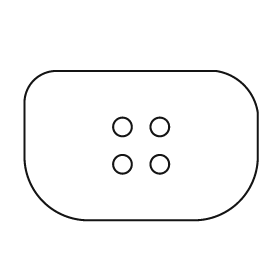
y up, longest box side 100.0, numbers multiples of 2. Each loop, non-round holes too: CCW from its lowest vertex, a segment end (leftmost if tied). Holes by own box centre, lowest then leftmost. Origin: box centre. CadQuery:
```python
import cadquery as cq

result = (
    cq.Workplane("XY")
    .moveTo(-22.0, -32.0)
    .lineTo(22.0, -32.0)
    .threePointArc((42.0, -24.0), (50.0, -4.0))
    .lineTo(50.0, 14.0)
    .threePointArc((44.0, 26.0), (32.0, 32.0))
    .lineTo(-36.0, 32.0)
    .threePointArc((-46.0, 28.0), (-50.0, 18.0))
    .lineTo(-50.0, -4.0)
    .threePointArc((-42.0, -24.0), (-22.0, -32.0))
    .close()
    .moveTo(-8.0, -8.0)
    .circle(4.0)
    .moveTo(8.0, -8.0)
    .circle(4.0)
    .moveTo(-8.0, 8.0)
    .circle(4.0)
    .moveTo(8.0, 8.0)
    .circle(4.0)
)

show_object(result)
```